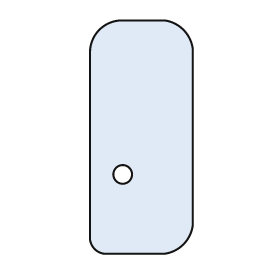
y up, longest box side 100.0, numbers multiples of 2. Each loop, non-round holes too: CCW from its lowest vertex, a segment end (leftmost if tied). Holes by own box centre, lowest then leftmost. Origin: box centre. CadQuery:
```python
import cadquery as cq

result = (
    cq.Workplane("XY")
    .moveTo(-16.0, -50.0)
    .lineTo(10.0, -50.0)
    .threePointArc((18.0, -46.0), (22.0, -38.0))
    .lineTo(22.0, 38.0)
    .threePointArc((18.0, 46.0), (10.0, 50.0))
    .lineTo(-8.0, 50.0)
    .threePointArc((-18.0, 46.0), (-22.0, 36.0))
    .lineTo(-22.0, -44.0)
    .threePointArc((-20.0, -48.0), (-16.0, -50.0))
    .close()
    .moveTo(-8.0, -16.0)
    .circle(4.0)
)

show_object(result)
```